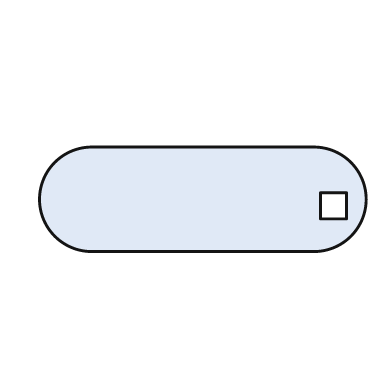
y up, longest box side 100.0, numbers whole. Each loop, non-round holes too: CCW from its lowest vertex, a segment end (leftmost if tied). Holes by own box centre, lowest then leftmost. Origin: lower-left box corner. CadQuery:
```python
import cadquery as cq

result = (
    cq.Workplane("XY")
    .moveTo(16.0, 0.0)
    .lineTo(84.0, 0.0)
    .threePointArc((100.0, 16.0), (84.0, 32.0))
    .lineTo(16.0, 32.0)
    .threePointArc((0.0, 16.0), (16.0, 0.0))
    .close()
    .moveTo(86.0, 10.0)
    .lineTo(94.0, 10.0)
    .lineTo(94.0, 18.0)
    .lineTo(86.0, 18.0)
    .close()
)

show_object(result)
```